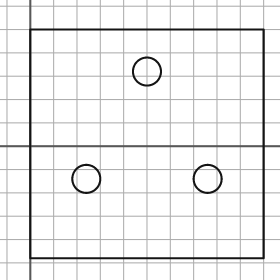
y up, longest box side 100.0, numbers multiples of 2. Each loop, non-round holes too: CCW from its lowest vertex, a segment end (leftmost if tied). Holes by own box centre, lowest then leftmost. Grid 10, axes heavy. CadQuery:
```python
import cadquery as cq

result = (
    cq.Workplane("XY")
    .moveTo(0.0, -48.0)
    .lineTo(100.0, -48.0)
    .lineTo(100.0, 50.0)
    .lineTo(0.0, 50.0)
    .close()
    .moveTo(24.0, -14.0)
    .circle(6.0)
    .moveTo(76.0, -14.0)
    .circle(6.0)
    .moveTo(50.0, 32.0)
    .circle(6.0)
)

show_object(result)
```